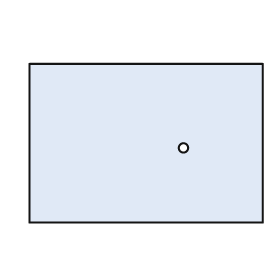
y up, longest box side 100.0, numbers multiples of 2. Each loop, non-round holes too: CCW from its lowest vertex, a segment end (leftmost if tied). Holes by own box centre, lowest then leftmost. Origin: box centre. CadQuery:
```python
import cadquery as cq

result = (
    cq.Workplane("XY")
    .moveTo(-50.0, -34.0)
    .lineTo(50.0, -34.0)
    .lineTo(50.0, 34.0)
    .lineTo(-50.0, 34.0)
    .close()
    .moveTo(16.0, -2.0)
    .circle(2.0)
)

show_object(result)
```